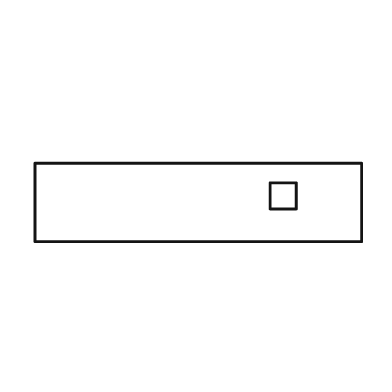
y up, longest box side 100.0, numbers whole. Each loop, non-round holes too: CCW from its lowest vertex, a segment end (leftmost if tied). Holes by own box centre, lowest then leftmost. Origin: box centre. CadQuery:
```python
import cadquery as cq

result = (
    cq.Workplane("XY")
    .moveTo(-50.0, -12.0)
    .lineTo(50.0, -12.0)
    .lineTo(50.0, 12.0)
    .lineTo(-50.0, 12.0)
    .close()
    .moveTo(22.0, -2.0)
    .lineTo(30.0, -2.0)
    .lineTo(30.0, 6.0)
    .lineTo(22.0, 6.0)
    .close()
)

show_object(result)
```